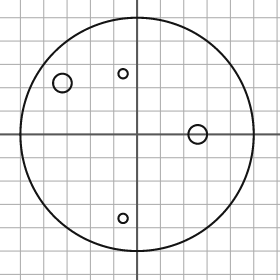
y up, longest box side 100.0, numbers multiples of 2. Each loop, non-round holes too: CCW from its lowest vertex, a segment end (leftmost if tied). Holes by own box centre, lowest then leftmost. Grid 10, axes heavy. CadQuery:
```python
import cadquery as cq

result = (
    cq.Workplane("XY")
    .moveTo(0.0, 0.0)
    .circle(50.0)
    .moveTo(-6.0, -36.0)
    .circle(2.0)
    .moveTo(26.0, 0.0)
    .circle(4.0)
    .moveTo(-32.0, 22.0)
    .circle(4.0)
    .moveTo(-6.0, 26.0)
    .circle(2.0)
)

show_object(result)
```